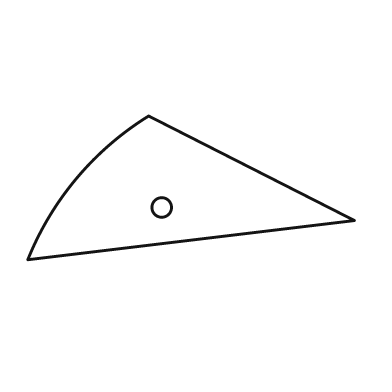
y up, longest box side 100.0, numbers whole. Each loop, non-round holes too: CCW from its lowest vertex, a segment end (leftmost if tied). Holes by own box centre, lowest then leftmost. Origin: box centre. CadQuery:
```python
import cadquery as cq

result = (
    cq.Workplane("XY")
    .moveTo(-50.0, -22.0)
    .lineTo(50.0, -10.0)
    .lineTo(-13.0, 22.0)
    .threePointArc((-35.0, 3.0), (-50.0, -22.0))
    .close()
    .moveTo(-9.0, -6.0)
    .circle(3.0)
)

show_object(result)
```